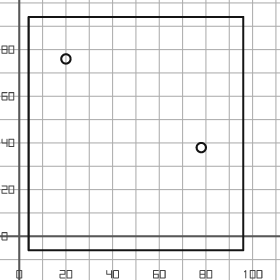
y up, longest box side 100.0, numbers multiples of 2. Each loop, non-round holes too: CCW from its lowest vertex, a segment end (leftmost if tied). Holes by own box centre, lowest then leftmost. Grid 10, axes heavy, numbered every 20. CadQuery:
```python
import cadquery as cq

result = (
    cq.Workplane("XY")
    .moveTo(4.0, -6.0)
    .lineTo(96.0, -6.0)
    .lineTo(96.0, 94.0)
    .lineTo(4.0, 94.0)
    .close()
    .moveTo(78.0, 38.0)
    .circle(2.0)
    .moveTo(20.0, 76.0)
    .circle(2.0)
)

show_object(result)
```